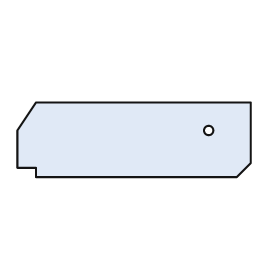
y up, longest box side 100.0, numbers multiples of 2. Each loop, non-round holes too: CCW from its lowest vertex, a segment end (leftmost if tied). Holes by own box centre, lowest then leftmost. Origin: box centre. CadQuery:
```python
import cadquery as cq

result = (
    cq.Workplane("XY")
    .moveTo(-42.0, -16.0)
    .lineTo(44.0, -16.0)
    .lineTo(50.0, -10.0)
    .lineTo(50.0, 16.0)
    .lineTo(-42.0, 16.0)
    .lineTo(-50.0, 4.0)
    .lineTo(-50.0, -12.0)
    .lineTo(-42.0, -12.0)
    .close()
    .moveTo(32.0, 4.0)
    .circle(2.0)
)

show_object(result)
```